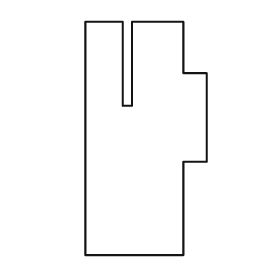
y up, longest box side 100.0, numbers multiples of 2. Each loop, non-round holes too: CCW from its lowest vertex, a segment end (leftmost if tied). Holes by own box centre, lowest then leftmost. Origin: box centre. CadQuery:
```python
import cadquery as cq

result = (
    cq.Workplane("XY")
    .moveTo(-26.0, -50.0)
    .lineTo(16.0, -50.0)
    .lineTo(16.0, -10.0)
    .lineTo(26.0, -10.0)
    .lineTo(26.0, 28.0)
    .lineTo(16.0, 28.0)
    .lineTo(16.0, 50.0)
    .lineTo(-6.0, 50.0)
    .lineTo(-6.0, 14.0)
    .lineTo(-10.0, 14.0)
    .lineTo(-10.0, 50.0)
    .lineTo(-26.0, 50.0)
    .close()
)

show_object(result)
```